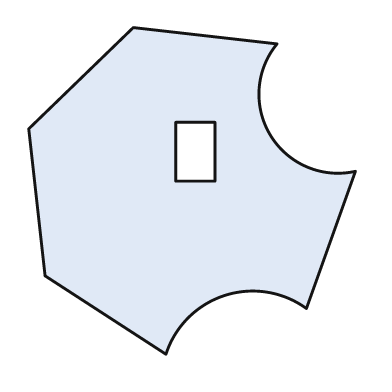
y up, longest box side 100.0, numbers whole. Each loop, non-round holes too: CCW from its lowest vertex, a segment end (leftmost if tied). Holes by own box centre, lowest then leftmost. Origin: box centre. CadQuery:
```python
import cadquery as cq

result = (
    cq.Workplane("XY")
    .moveTo(-8.0, -50.0)
    .threePointArc((10.0, -32.0), (35.0, -36.0))
    .lineTo(50.0, 6.0)
    .threePointArc((24.0, 17.0), (26.0, 45.0))
    .lineTo(-18.0, 50.0)
    .lineTo(-50.0, 19.0)
    .lineTo(-45.0, -26.0)
    .close()
    .moveTo(-5.0, 3.0)
    .lineTo(7.0, 3.0)
    .lineTo(7.0, 21.0)
    .lineTo(-5.0, 21.0)
    .close()
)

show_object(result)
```